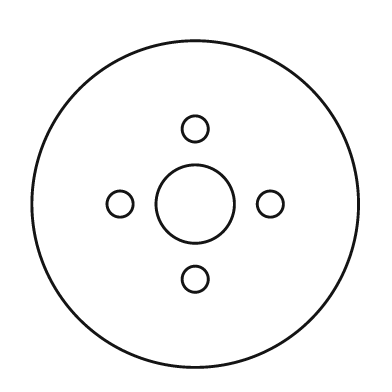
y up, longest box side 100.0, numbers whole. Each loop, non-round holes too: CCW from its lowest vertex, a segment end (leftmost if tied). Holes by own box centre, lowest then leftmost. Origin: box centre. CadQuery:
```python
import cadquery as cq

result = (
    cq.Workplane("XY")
    .moveTo(0.0, 0.0)
    .circle(50.0)
    .moveTo(0.0, -23.0)
    .circle(4.0)
    .moveTo(-23.0, 0.0)
    .circle(4.0)
    .moveTo(0.0, 0.0)
    .circle(12.0)
    .moveTo(23.0, 0.0)
    .circle(4.0)
    .moveTo(0.0, 23.0)
    .circle(4.0)
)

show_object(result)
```